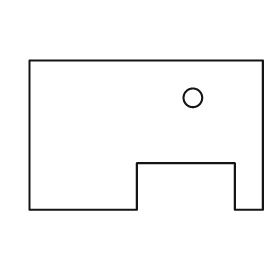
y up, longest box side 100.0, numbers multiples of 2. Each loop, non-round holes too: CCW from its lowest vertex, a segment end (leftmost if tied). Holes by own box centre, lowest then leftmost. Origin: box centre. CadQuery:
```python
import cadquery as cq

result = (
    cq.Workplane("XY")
    .moveTo(-50.0, -32.0)
    .lineTo(-4.0, -32.0)
    .lineTo(-4.0, -12.0)
    .lineTo(38.0, -12.0)
    .lineTo(38.0, -32.0)
    .lineTo(50.0, -32.0)
    .lineTo(50.0, 32.0)
    .lineTo(-50.0, 32.0)
    .close()
    .moveTo(20.0, 16.0)
    .circle(4.0)
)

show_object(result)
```